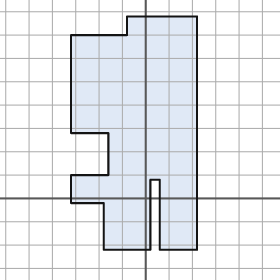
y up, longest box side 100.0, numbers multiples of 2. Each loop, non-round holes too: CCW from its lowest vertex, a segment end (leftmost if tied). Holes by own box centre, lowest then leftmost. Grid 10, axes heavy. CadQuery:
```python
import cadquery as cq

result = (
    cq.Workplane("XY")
    .moveTo(-18.0, -22.0)
    .lineTo(2.0, -22.0)
    .lineTo(2.0, 8.0)
    .lineTo(6.0, 8.0)
    .lineTo(6.0, -22.0)
    .lineTo(22.0, -22.0)
    .lineTo(22.0, 78.0)
    .lineTo(-8.0, 78.0)
    .lineTo(-8.0, 70.0)
    .lineTo(-32.0, 70.0)
    .lineTo(-32.0, 28.0)
    .lineTo(-16.0, 28.0)
    .lineTo(-16.0, 10.0)
    .lineTo(-32.0, 10.0)
    .lineTo(-32.0, -2.0)
    .lineTo(-18.0, -2.0)
    .close()
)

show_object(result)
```